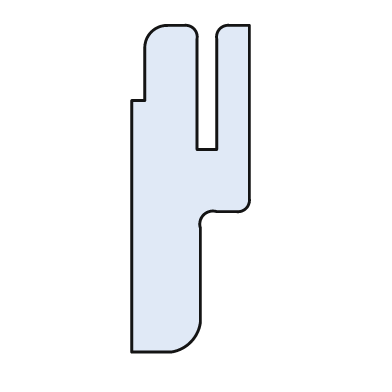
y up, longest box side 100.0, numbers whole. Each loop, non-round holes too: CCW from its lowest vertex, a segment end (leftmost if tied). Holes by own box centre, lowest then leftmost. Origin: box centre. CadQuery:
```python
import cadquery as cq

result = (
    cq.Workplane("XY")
    .moveTo(-18.0, -50.0)
    .lineTo(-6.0, -50.0)
    .threePointArc((0.0, -47.0), (3.0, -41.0))
    .lineTo(3.0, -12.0)
    .threePointArc((4.0, -8.0), (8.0, -7.0))
    .lineTo(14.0, -7.0)
    .threePointArc((17.0, -6.0), (18.0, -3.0))
    .lineTo(18.0, 50.0)
    .lineTo(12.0, 50.0)
    .threePointArc((9.0, 49.0), (8.0, 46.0))
    .lineTo(8.0, 12.0)
    .lineTo(2.0, 12.0)
    .lineTo(2.0, 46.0)
    .threePointArc((1.0, 49.0), (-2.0, 50.0))
    .lineTo(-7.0, 50.0)
    .threePointArc((-12.0, 48.0), (-14.0, 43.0))
    .lineTo(-14.0, 27.0)
    .lineTo(-18.0, 27.0)
    .close()
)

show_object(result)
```